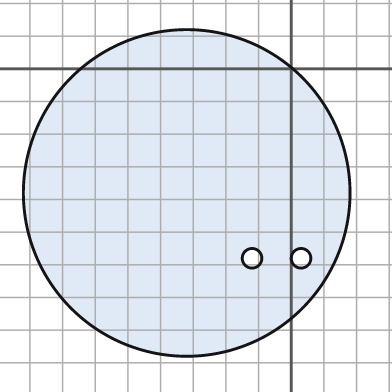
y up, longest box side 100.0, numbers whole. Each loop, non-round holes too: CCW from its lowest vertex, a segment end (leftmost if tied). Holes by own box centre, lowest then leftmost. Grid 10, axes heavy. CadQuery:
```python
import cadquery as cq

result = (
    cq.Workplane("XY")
    .moveTo(-32.0, -38.0)
    .circle(50.0)
    .moveTo(-12.0, -58.0)
    .circle(3.0)
    .moveTo(3.0, -58.0)
    .circle(3.0)
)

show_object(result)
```